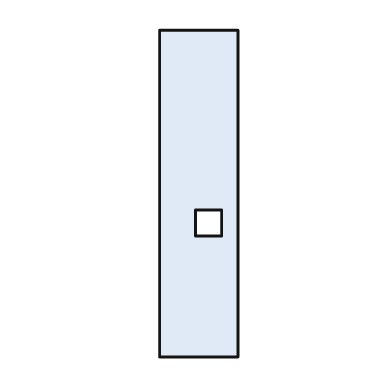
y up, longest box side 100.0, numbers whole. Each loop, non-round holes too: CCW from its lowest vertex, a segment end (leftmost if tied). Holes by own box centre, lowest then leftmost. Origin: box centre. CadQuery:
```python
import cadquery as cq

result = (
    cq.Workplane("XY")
    .moveTo(-12.0, -50.0)
    .lineTo(12.0, -50.0)
    .lineTo(12.0, 50.0)
    .lineTo(-12.0, 50.0)
    .close()
    .moveTo(-1.0, -13.0)
    .lineTo(7.0, -13.0)
    .lineTo(7.0, -5.0)
    .lineTo(-1.0, -5.0)
    .close()
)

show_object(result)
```